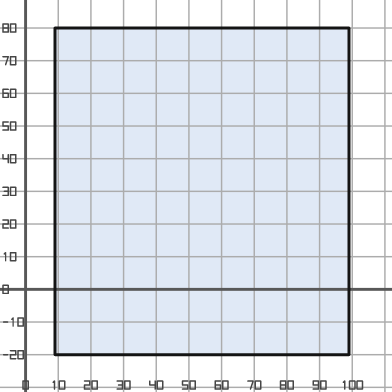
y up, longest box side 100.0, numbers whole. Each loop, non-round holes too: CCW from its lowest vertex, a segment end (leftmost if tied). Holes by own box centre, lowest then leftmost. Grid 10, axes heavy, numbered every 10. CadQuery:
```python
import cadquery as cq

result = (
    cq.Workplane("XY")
    .moveTo(9.0, -20.0)
    .lineTo(99.0, -20.0)
    .lineTo(99.0, 80.0)
    .lineTo(9.0, 80.0)
    .close()
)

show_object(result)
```